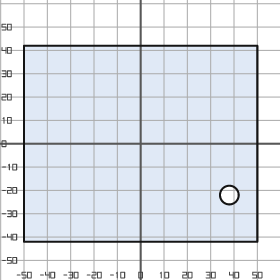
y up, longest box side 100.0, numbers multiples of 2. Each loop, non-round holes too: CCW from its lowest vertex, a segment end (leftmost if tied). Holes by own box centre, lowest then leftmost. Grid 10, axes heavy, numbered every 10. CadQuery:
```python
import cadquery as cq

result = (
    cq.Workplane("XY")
    .moveTo(-50.0, -42.0)
    .lineTo(50.0, -42.0)
    .lineTo(50.0, 42.0)
    .lineTo(-50.0, 42.0)
    .close()
    .moveTo(38.0, -22.0)
    .circle(4.0)
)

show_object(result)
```